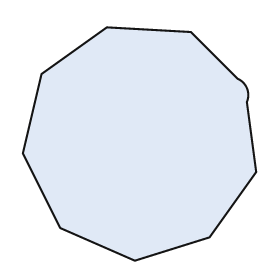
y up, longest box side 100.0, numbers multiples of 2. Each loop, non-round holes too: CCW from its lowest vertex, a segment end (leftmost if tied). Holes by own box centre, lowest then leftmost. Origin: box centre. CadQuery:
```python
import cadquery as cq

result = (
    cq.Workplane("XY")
    .moveTo(-2.0, -50.0)
    .lineTo(30.0, -40.0)
    .lineTo(50.0, -12.0)
    .lineTo(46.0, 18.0)
    .threePointArc((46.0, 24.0), (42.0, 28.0))
    .lineTo(22.0, 48.0)
    .lineTo(-14.0, 50.0)
    .lineTo(-42.0, 30.0)
    .lineTo(-50.0, -4.0)
    .lineTo(-34.0, -36.0)
    .close()
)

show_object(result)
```